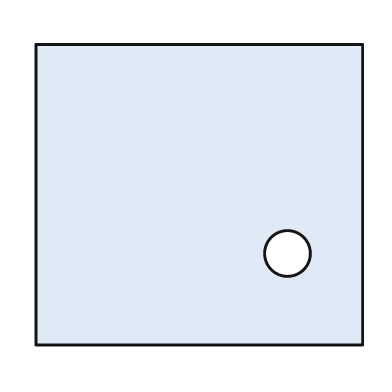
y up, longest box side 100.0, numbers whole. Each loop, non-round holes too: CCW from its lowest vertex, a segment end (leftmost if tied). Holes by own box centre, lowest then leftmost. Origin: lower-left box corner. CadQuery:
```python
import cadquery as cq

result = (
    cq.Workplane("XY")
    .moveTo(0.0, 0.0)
    .lineTo(100.0, 0.0)
    .lineTo(100.0, 92.0)
    .lineTo(0.0, 92.0)
    .close()
    .moveTo(77.0, 28.0)
    .circle(7.0)
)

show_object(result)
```